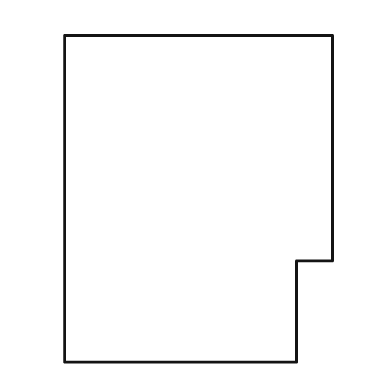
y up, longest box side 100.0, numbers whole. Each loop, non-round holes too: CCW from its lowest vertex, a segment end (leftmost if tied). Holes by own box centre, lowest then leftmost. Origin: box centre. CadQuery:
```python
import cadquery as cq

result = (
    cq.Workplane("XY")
    .moveTo(-41.0, -50.0)
    .lineTo(30.0, -50.0)
    .lineTo(30.0, -19.0)
    .lineTo(41.0, -19.0)
    .lineTo(41.0, 50.0)
    .lineTo(-41.0, 50.0)
    .close()
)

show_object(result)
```